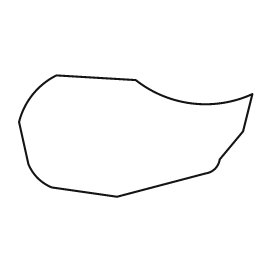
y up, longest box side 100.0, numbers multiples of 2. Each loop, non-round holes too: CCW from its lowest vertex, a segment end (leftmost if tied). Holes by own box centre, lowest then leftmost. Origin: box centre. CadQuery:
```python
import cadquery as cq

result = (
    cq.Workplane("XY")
    .moveTo(-8.0, -26.0)
    .lineTo(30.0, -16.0)
    .threePointArc((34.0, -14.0), (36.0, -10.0))
    .lineTo(46.0, 2.0)
    .lineTo(50.0, 18.0)
    .threePointArc((24.0, 14.0), (0.0, 24.0))
    .lineTo(-34.0, 26.0)
    .threePointArc((-44.0, 18.0), (-50.0, 6.0))
    .lineTo(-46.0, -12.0)
    .threePointArc((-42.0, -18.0), (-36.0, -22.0))
    .close()
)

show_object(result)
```